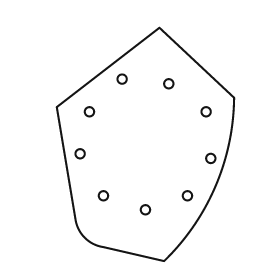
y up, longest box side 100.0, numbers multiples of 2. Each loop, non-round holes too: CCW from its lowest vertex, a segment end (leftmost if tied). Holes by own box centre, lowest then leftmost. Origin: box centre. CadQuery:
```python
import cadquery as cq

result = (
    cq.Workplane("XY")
    .moveTo(8.0, -50.0)
    .threePointArc((30.0, -18.0), (38.0, 20.0))
    .lineTo(6.0, 50.0)
    .lineTo(-38.0, 16.0)
    .lineTo(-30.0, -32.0)
    .threePointArc((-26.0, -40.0), (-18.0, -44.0))
    .close()
    .moveTo(0.0, -28.0)
    .circle(2.0)
    .moveTo(-18.0, -22.0)
    .circle(2.0)
    .moveTo(18.0, -22.0)
    .circle(2.0)
    .moveTo(28.0, -6.0)
    .circle(2.0)
    .moveTo(-28.0, -4.0)
    .circle(2.0)
    .moveTo(-24.0, 14.0)
    .circle(2.0)
    .moveTo(26.0, 14.0)
    .circle(2.0)
    .moveTo(10.0, 26.0)
    .circle(2.0)
    .moveTo(-10.0, 28.0)
    .circle(2.0)
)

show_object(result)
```